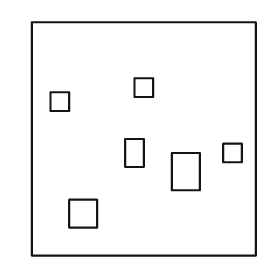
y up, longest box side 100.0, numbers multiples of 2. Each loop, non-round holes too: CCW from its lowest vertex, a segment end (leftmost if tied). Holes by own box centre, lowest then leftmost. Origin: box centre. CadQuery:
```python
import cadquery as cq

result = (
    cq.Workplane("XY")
    .moveTo(-48.0, -50.0)
    .lineTo(48.0, -50.0)
    .lineTo(48.0, 50.0)
    .lineTo(-48.0, 50.0)
    .close()
    .moveTo(-32.0, -38.0)
    .lineTo(-20.0, -38.0)
    .lineTo(-20.0, -26.0)
    .lineTo(-32.0, -26.0)
    .close()
    .moveTo(12.0, -22.0)
    .lineTo(24.0, -22.0)
    .lineTo(24.0, -6.0)
    .lineTo(12.0, -6.0)
    .close()
    .moveTo(-8.0, -12.0)
    .lineTo(0.0, -12.0)
    .lineTo(0.0, 0.0)
    .lineTo(-8.0, 0.0)
    .close()
    .moveTo(34.0, -10.0)
    .lineTo(42.0, -10.0)
    .lineTo(42.0, -2.0)
    .lineTo(34.0, -2.0)
    .close()
    .moveTo(-40.0, 12.0)
    .lineTo(-32.0, 12.0)
    .lineTo(-32.0, 20.0)
    .lineTo(-40.0, 20.0)
    .close()
    .moveTo(-4.0, 18.0)
    .lineTo(4.0, 18.0)
    .lineTo(4.0, 26.0)
    .lineTo(-4.0, 26.0)
    .close()
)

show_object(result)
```